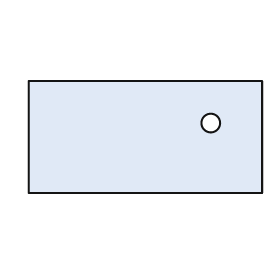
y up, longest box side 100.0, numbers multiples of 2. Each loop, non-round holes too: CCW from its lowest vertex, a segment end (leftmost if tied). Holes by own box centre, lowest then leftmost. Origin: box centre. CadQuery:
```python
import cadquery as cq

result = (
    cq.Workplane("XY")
    .moveTo(-50.0, -24.0)
    .lineTo(50.0, -24.0)
    .lineTo(50.0, 24.0)
    .lineTo(-50.0, 24.0)
    .close()
    .moveTo(28.0, 6.0)
    .circle(4.0)
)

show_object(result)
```